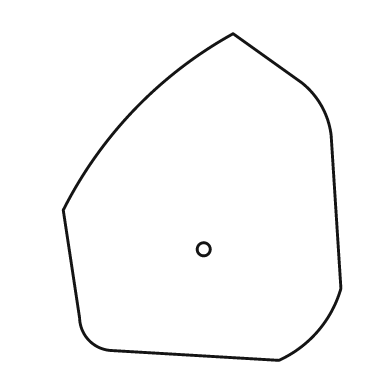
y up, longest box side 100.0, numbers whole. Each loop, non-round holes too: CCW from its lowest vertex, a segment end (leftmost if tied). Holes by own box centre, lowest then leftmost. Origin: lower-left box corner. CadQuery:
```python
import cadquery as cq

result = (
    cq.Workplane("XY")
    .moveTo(66.0, 0.0)
    .threePointArc((78.0, 9.0), (85.0, 22.0))
    .lineTo(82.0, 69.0)
    .threePointArc((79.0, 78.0), (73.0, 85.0))
    .lineTo(52.0, 100.0)
    .threePointArc((22.0, 77.0), (0.0, 46.0))
    .lineTo(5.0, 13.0)
    .threePointArc((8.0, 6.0), (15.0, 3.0))
    .close()
    .moveTo(43.0, 34.0)
    .circle(2.0)
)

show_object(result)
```